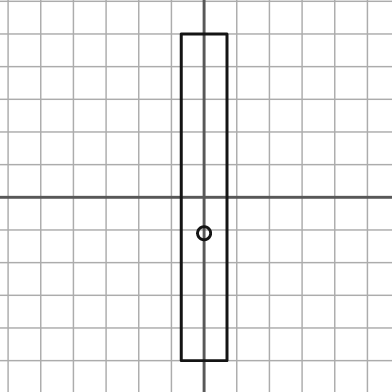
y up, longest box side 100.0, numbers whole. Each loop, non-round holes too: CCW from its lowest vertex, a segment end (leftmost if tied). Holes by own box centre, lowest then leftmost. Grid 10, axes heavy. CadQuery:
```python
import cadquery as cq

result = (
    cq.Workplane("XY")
    .moveTo(-7.0, -50.0)
    .lineTo(7.0, -50.0)
    .lineTo(7.0, 50.0)
    .lineTo(-7.0, 50.0)
    .close()
    .moveTo(0.0, -11.0)
    .circle(2.0)
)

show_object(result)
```